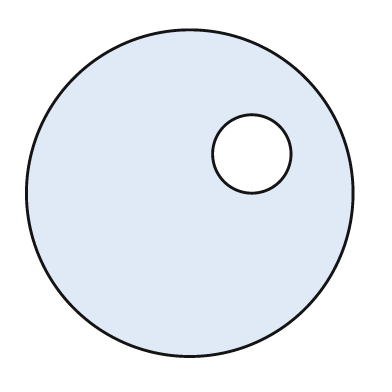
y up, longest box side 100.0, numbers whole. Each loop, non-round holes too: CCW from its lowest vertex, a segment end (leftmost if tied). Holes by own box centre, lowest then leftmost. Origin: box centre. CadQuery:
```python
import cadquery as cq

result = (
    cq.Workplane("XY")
    .moveTo(0.0, 0.0)
    .circle(50.0)
    .moveTo(19.0, 12.0)
    .circle(12.0)
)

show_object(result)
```